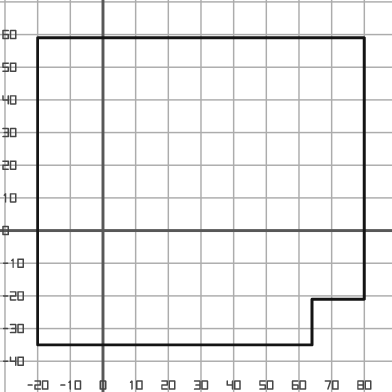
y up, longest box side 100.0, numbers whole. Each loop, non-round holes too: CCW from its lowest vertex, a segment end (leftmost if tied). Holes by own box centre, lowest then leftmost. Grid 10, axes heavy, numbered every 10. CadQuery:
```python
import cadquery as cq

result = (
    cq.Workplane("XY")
    .moveTo(-20.0, -35.0)
    .lineTo(64.0, -35.0)
    .lineTo(64.0, -21.0)
    .lineTo(80.0, -21.0)
    .lineTo(80.0, 59.0)
    .lineTo(-20.0, 59.0)
    .close()
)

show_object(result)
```